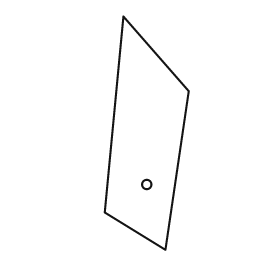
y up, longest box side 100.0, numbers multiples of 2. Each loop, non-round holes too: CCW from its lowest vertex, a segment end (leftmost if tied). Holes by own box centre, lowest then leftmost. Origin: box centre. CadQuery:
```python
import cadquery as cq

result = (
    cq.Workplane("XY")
    .moveTo(8.0, -50.0)
    .lineTo(18.0, 18.0)
    .lineTo(-10.0, 50.0)
    .lineTo(-18.0, -34.0)
    .close()
    .moveTo(0.0, -22.0)
    .circle(2.0)
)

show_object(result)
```